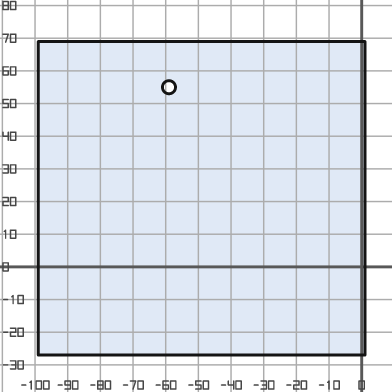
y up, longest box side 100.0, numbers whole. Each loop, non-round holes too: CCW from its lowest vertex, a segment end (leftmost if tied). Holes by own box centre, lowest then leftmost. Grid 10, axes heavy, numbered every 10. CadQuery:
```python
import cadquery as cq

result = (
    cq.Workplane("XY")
    .moveTo(-99.0, -27.0)
    .lineTo(1.0, -27.0)
    .lineTo(1.0, 69.0)
    .lineTo(-99.0, 69.0)
    .close()
    .moveTo(-59.0, 55.0)
    .circle(2.0)
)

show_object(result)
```